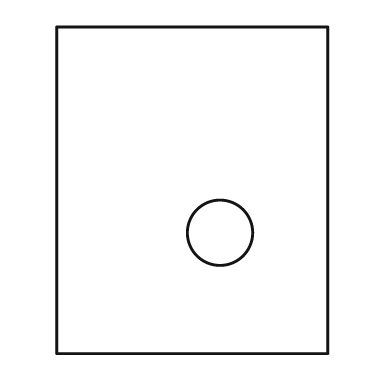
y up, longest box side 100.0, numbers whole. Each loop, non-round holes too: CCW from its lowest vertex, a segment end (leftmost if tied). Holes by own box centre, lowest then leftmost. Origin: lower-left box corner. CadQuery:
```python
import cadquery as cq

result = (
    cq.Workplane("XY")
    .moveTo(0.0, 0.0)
    .lineTo(83.0, 0.0)
    .lineTo(83.0, 100.0)
    .lineTo(0.0, 100.0)
    .close()
    .moveTo(50.0, 37.0)
    .circle(10.0)
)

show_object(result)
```